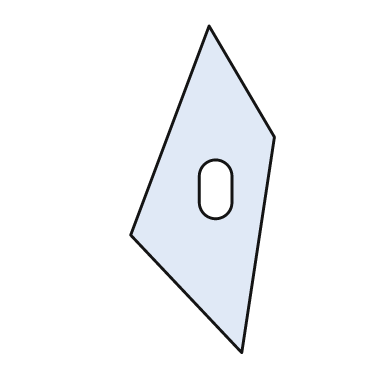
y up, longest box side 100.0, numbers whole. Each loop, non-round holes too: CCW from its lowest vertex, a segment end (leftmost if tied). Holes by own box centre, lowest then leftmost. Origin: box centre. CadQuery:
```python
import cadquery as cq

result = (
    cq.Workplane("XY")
    .moveTo(12.0, -50.0)
    .lineTo(22.0, 16.0)
    .lineTo(2.0, 50.0)
    .lineTo(-22.0, -14.0)
    .close()
    .moveTo(-1.0, -4.0)
    .threePointArc((4.0, -9.0), (9.0, -4.0))
    .lineTo(9.0, 4.0)
    .threePointArc((4.0, 9.0), (-1.0, 4.0))
    .close()
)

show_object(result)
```